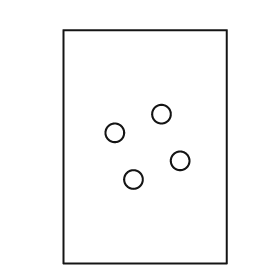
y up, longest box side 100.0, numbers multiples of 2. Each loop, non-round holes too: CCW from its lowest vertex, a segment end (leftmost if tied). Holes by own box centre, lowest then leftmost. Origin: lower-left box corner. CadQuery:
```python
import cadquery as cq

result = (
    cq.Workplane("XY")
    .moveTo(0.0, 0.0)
    .lineTo(70.0, 0.0)
    .lineTo(70.0, 100.0)
    .lineTo(0.0, 100.0)
    .close()
    .moveTo(30.0, 36.0)
    .circle(4.0)
    .moveTo(50.0, 44.0)
    .circle(4.0)
    .moveTo(22.0, 56.0)
    .circle(4.0)
    .moveTo(42.0, 64.0)
    .circle(4.0)
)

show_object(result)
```